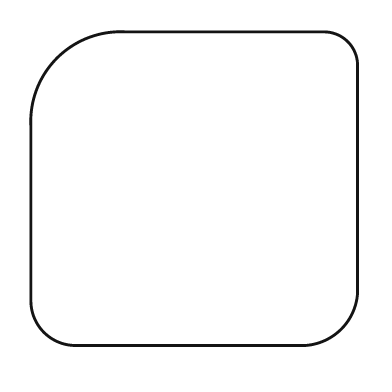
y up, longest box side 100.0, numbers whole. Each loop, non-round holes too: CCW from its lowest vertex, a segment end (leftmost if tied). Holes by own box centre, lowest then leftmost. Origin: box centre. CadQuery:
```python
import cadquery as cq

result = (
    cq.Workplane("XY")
    .moveTo(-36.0, -48.0)
    .lineTo(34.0, -48.0)
    .threePointArc((45.0, -43.0), (50.0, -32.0))
    .lineTo(50.0, 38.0)
    .threePointArc((47.0, 45.0), (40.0, 48.0))
    .lineTo(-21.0, 48.0)
    .threePointArc((-42.0, 40.0), (-50.0, 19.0))
    .lineTo(-50.0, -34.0)
    .threePointArc((-46.0, -44.0), (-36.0, -48.0))
    .close()
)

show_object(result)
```